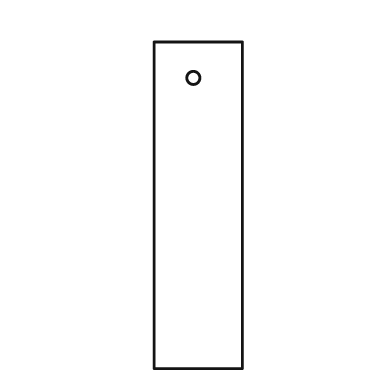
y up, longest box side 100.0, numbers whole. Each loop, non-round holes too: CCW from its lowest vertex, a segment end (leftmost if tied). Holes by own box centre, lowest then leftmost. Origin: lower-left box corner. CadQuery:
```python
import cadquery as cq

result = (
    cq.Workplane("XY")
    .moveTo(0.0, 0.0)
    .lineTo(27.0, 0.0)
    .lineTo(27.0, 100.0)
    .lineTo(0.0, 100.0)
    .close()
    .moveTo(12.0, 89.0)
    .circle(2.0)
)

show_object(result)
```